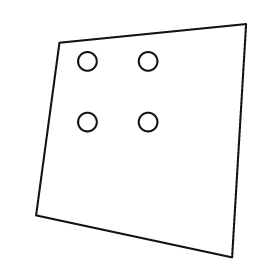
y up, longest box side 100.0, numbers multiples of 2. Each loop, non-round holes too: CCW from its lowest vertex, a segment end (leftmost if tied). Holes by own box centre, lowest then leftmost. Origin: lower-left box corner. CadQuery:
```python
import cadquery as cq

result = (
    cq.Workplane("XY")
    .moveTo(84.0, 0.0)
    .lineTo(90.0, 100.0)
    .lineTo(10.0, 92.0)
    .lineTo(0.0, 18.0)
    .close()
    .moveTo(22.0, 58.0)
    .circle(4.0)
    .moveTo(48.0, 58.0)
    .circle(4.0)
    .moveTo(22.0, 84.0)
    .circle(4.0)
    .moveTo(48.0, 84.0)
    .circle(4.0)
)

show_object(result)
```